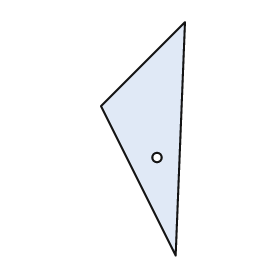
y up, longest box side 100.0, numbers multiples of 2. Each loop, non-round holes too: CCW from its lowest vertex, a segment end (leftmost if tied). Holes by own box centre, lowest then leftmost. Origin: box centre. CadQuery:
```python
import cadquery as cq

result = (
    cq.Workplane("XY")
    .moveTo(14.0, -50.0)
    .lineTo(18.0, 50.0)
    .lineTo(-18.0, 14.0)
    .close()
    .moveTo(6.0, -8.0)
    .circle(2.0)
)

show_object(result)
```